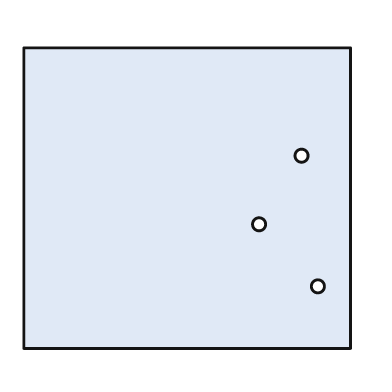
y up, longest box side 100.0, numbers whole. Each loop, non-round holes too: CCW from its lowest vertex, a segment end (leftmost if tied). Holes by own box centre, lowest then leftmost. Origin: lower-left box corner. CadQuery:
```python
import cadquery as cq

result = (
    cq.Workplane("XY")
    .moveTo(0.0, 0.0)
    .lineTo(100.0, 0.0)
    .lineTo(100.0, 92.0)
    .lineTo(0.0, 92.0)
    .close()
    .moveTo(90.0, 19.0)
    .circle(2.0)
    .moveTo(72.0, 38.0)
    .circle(2.0)
    .moveTo(85.0, 59.0)
    .circle(2.0)
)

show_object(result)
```